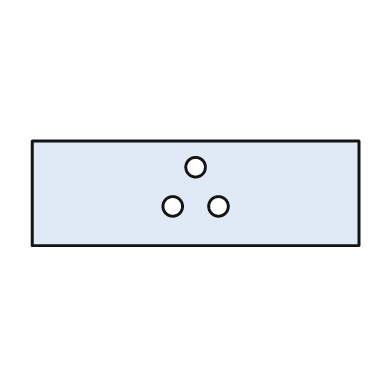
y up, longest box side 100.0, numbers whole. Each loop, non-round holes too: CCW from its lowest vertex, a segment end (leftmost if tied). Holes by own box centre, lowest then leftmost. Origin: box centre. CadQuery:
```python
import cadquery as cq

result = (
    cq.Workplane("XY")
    .moveTo(-50.0, -16.0)
    .lineTo(50.0, -16.0)
    .lineTo(50.0, 16.0)
    .lineTo(-50.0, 16.0)
    .close()
    .moveTo(-7.0, -4.0)
    .circle(3.0)
    .moveTo(7.0, -4.0)
    .circle(3.0)
    .moveTo(0.0, 8.0)
    .circle(3.0)
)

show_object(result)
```